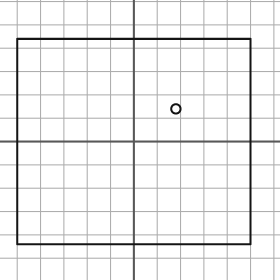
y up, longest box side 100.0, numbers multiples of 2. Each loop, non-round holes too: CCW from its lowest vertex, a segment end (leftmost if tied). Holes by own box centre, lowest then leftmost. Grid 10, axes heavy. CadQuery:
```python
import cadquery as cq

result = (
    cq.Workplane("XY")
    .moveTo(-50.0, -44.0)
    .lineTo(50.0, -44.0)
    .lineTo(50.0, 44.0)
    .lineTo(-50.0, 44.0)
    .close()
    .moveTo(18.0, 14.0)
    .circle(2.0)
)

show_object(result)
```